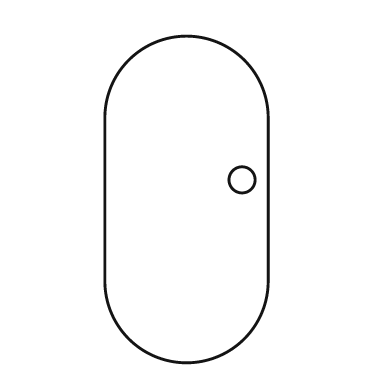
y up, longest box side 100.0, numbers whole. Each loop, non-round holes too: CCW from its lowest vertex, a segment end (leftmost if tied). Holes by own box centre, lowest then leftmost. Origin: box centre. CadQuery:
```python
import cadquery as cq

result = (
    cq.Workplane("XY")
    .moveTo(-25.0, -25.0)
    .threePointArc((0.0, -50.0), (25.0, -25.0))
    .lineTo(25.0, 25.0)
    .threePointArc((0.0, 50.0), (-25.0, 25.0))
    .close()
    .moveTo(17.0, 6.0)
    .circle(4.0)
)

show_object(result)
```